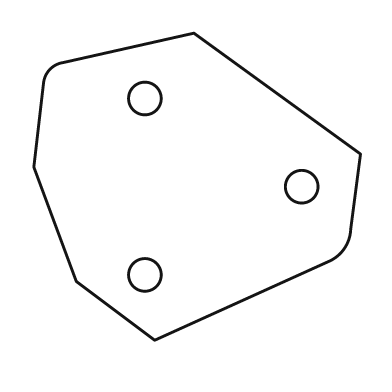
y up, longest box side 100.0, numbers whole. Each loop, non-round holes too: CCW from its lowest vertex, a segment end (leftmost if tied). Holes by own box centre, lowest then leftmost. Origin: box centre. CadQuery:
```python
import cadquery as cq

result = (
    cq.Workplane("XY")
    .moveTo(-13.0, -47.0)
    .lineTo(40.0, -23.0)
    .threePointArc((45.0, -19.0), (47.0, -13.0))
    .lineTo(50.0, 10.0)
    .lineTo(-1.0, 47.0)
    .lineTo(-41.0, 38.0)
    .threePointArc((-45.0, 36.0), (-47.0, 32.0))
    .lineTo(-50.0, 6.0)
    .lineTo(-37.0, -29.0)
    .close()
    .moveTo(-16.0, -27.0)
    .circle(5.0)
    .moveTo(32.0, 0.0)
    .circle(5.0)
    .moveTo(-16.0, 27.0)
    .circle(5.0)
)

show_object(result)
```